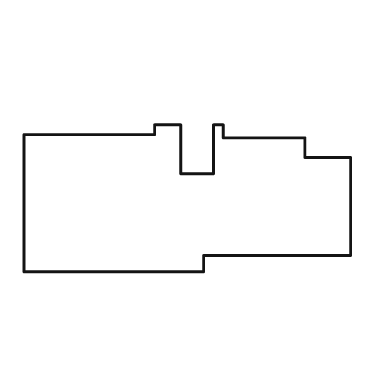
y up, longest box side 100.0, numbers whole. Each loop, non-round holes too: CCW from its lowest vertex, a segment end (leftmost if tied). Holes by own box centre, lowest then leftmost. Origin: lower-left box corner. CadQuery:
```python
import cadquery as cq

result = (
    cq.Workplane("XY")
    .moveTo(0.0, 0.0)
    .lineTo(55.0, 0.0)
    .lineTo(55.0, 5.0)
    .lineTo(100.0, 5.0)
    .lineTo(100.0, 35.0)
    .lineTo(86.0, 35.0)
    .lineTo(86.0, 41.0)
    .lineTo(61.0, 41.0)
    .lineTo(61.0, 45.0)
    .lineTo(58.0, 45.0)
    .lineTo(58.0, 30.0)
    .lineTo(48.0, 30.0)
    .lineTo(48.0, 45.0)
    .lineTo(40.0, 45.0)
    .lineTo(40.0, 42.0)
    .lineTo(0.0, 42.0)
    .close()
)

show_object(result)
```